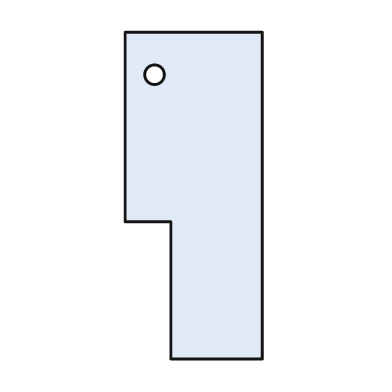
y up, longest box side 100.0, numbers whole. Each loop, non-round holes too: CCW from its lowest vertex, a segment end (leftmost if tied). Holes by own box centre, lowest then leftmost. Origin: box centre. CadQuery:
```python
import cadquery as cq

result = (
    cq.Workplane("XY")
    .moveTo(-7.0, -50.0)
    .lineTo(21.0, -50.0)
    .lineTo(21.0, 50.0)
    .lineTo(-21.0, 50.0)
    .lineTo(-21.0, -8.0)
    .lineTo(-7.0, -8.0)
    .close()
    .moveTo(-12.0, 37.0)
    .circle(3.0)
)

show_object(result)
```